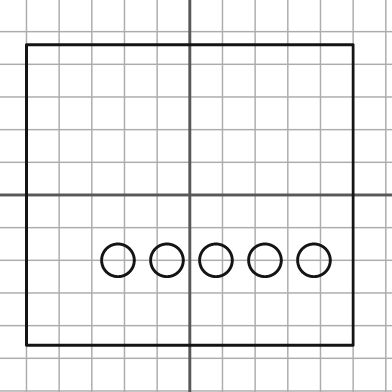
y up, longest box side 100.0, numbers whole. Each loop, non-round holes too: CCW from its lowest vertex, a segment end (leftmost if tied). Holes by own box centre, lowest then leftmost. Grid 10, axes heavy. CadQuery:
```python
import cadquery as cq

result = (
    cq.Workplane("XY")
    .moveTo(-50.0, -46.0)
    .lineTo(50.0, -46.0)
    .lineTo(50.0, 46.0)
    .lineTo(-50.0, 46.0)
    .close()
    .moveTo(-22.0, -20.0)
    .circle(5.0)
    .moveTo(-7.0, -20.0)
    .circle(5.0)
    .moveTo(8.0, -20.0)
    .circle(5.0)
    .moveTo(23.0, -20.0)
    .circle(5.0)
    .moveTo(38.0, -20.0)
    .circle(5.0)
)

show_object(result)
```